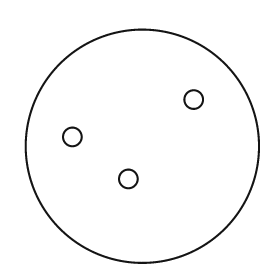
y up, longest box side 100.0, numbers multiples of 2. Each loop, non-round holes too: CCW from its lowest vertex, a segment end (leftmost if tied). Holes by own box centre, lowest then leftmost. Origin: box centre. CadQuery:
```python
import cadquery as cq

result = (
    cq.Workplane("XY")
    .moveTo(0.0, 0.0)
    .circle(50.0)
    .moveTo(-6.0, -14.0)
    .circle(4.0)
    .moveTo(-30.0, 4.0)
    .circle(4.0)
    .moveTo(22.0, 20.0)
    .circle(4.0)
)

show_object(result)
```